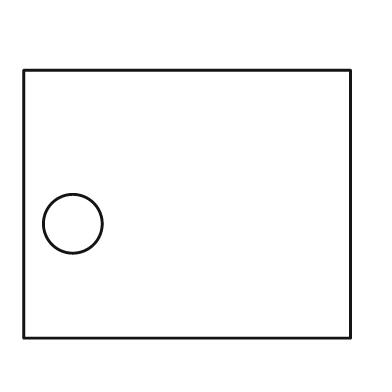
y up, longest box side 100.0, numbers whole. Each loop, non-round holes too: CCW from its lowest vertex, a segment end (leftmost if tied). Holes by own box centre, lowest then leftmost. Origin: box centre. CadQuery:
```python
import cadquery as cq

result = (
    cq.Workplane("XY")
    .moveTo(-50.0, -41.0)
    .lineTo(50.0, -41.0)
    .lineTo(50.0, 41.0)
    .lineTo(-50.0, 41.0)
    .close()
    .moveTo(-35.0, -6.0)
    .circle(9.0)
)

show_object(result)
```